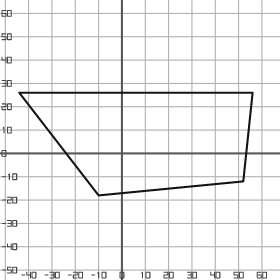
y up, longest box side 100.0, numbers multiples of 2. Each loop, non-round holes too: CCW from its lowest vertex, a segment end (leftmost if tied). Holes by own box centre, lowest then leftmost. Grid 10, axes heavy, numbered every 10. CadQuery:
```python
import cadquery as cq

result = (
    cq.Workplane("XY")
    .moveTo(-10.0, -18.0)
    .lineTo(52.0, -12.0)
    .lineTo(56.0, 26.0)
    .lineTo(-44.0, 26.0)
    .close()
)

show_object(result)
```